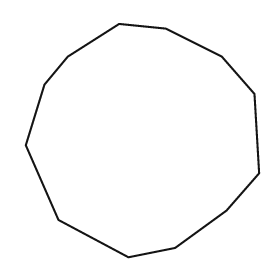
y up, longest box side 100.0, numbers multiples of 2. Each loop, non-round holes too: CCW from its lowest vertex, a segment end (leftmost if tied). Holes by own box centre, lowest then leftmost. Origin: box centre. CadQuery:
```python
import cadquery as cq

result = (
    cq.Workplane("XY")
    .moveTo(-6.0, -50.0)
    .lineTo(14.0, -46.0)
    .lineTo(36.0, -30.0)
    .lineTo(50.0, -14.0)
    .lineTo(48.0, 20.0)
    .lineTo(34.0, 36.0)
    .lineTo(10.0, 48.0)
    .lineTo(-10.0, 50.0)
    .lineTo(-32.0, 36.0)
    .lineTo(-42.0, 24.0)
    .lineTo(-50.0, -2.0)
    .lineTo(-36.0, -34.0)
    .close()
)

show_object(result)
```